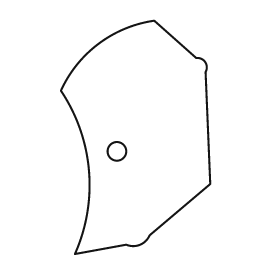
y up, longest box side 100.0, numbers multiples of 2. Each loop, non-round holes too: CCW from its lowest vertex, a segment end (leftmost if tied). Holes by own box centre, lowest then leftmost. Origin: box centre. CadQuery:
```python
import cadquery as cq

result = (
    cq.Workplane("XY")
    .moveTo(-26.0, -50.0)
    .lineTo(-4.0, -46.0)
    .threePointArc((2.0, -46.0), (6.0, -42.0))
    .lineTo(32.0, -20.0)
    .lineTo(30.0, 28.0)
    .threePointArc((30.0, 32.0), (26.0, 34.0))
    .lineTo(8.0, 50.0)
    .threePointArc((-16.0, 40.0), (-32.0, 20.0))
    .threePointArc((-20.0, -14.0), (-26.0, -50.0))
    .close()
    .moveTo(-8.0, -6.0)
    .circle(4.0)
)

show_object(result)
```